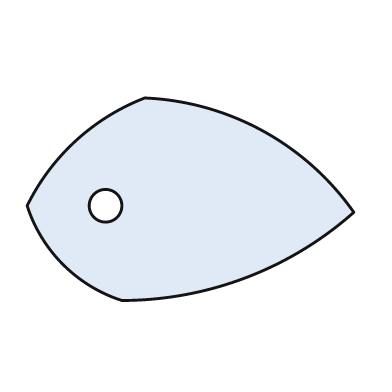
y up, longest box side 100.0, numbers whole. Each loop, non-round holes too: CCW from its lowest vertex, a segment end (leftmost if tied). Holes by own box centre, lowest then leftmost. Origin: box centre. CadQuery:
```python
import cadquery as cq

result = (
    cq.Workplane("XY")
    .moveTo(-21.0, -31.0)
    .threePointArc((17.0, -24.0), (50.0, -4.0))
    .threePointArc((22.0, 21.0), (-14.0, 31.0))
    .threePointArc((-35.0, 18.0), (-50.0, -2.0))
    .threePointArc((-39.0, -20.0), (-21.0, -31.0))
    .close()
    .moveTo(-26.0, -2.0)
    .circle(5.0)
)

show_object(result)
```